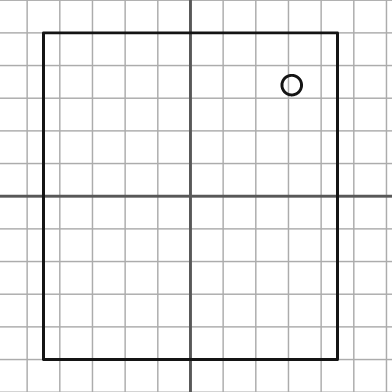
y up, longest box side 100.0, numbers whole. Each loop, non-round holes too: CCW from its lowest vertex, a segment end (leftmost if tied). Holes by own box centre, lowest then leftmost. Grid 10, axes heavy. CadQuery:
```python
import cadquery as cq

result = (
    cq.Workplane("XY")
    .moveTo(-45.0, -50.0)
    .lineTo(45.0, -50.0)
    .lineTo(45.0, 50.0)
    .lineTo(-45.0, 50.0)
    .close()
    .moveTo(31.0, 34.0)
    .circle(3.0)
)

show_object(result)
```